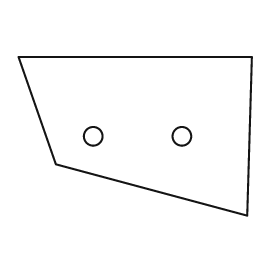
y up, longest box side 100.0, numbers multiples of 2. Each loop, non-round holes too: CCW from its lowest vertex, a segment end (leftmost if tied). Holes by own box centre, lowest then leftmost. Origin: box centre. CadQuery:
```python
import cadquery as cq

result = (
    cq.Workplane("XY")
    .moveTo(48.0, -34.0)
    .lineTo(50.0, 34.0)
    .lineTo(-50.0, 34.0)
    .lineTo(-34.0, -12.0)
    .close()
    .moveTo(-18.0, 0.0)
    .circle(4.0)
    .moveTo(20.0, 0.0)
    .circle(4.0)
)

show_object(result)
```